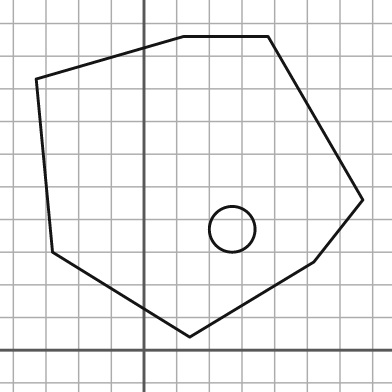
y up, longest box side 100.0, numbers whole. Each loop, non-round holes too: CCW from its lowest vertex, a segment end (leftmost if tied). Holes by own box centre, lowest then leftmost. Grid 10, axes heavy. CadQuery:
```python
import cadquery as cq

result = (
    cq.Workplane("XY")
    .moveTo(14.0, 4.0)
    .lineTo(52.0, 27.0)
    .lineTo(67.0, 46.0)
    .lineTo(38.0, 96.0)
    .lineTo(12.0, 96.0)
    .lineTo(-33.0, 83.0)
    .lineTo(-28.0, 30.0)
    .close()
    .moveTo(27.0, 37.0)
    .circle(7.0)
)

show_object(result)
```